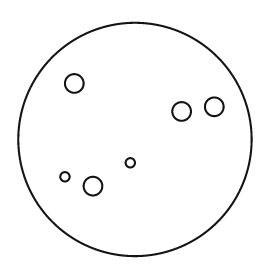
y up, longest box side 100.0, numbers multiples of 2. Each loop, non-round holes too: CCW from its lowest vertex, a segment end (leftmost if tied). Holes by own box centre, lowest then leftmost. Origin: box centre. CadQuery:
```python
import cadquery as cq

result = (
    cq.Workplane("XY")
    .moveTo(0.0, 0.0)
    .circle(50.0)
    .moveTo(-18.0, -20.0)
    .circle(4.0)
    .moveTo(-30.0, -16.0)
    .circle(2.0)
    .moveTo(-2.0, -10.0)
    .circle(2.0)
    .moveTo(20.0, 12.0)
    .circle(4.0)
    .moveTo(34.0, 14.0)
    .circle(4.0)
    .moveTo(-26.0, 24.0)
    .circle(4.0)
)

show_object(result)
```